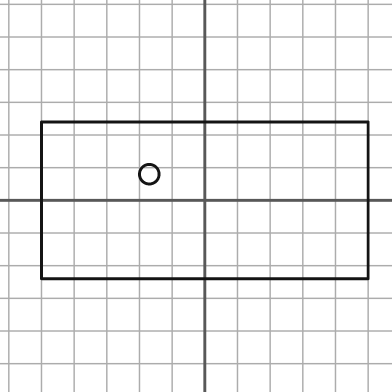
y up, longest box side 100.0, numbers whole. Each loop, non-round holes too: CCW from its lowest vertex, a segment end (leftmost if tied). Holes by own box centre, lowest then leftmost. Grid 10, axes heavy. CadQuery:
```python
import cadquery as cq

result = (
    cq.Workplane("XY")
    .moveTo(-50.0, -24.0)
    .lineTo(50.0, -24.0)
    .lineTo(50.0, 24.0)
    .lineTo(-50.0, 24.0)
    .close()
    .moveTo(-17.0, 8.0)
    .circle(3.0)
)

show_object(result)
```